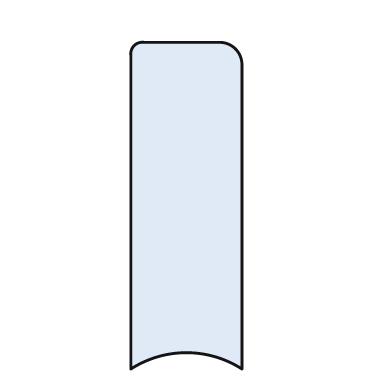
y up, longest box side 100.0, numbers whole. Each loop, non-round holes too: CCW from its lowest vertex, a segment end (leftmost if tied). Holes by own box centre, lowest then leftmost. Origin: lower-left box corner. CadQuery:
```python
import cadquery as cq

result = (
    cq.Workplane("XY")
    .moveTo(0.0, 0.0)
    .threePointArc((17.0, 5.0), (34.0, 0.0))
    .lineTo(34.0, 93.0)
    .threePointArc((32.0, 98.0), (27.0, 100.0))
    .lineTo(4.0, 100.0)
    .threePointArc((1.0, 99.0), (0.0, 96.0))
    .close()
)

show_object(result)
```